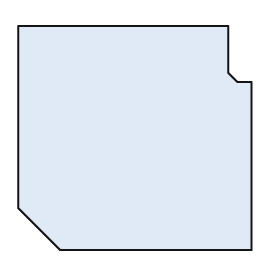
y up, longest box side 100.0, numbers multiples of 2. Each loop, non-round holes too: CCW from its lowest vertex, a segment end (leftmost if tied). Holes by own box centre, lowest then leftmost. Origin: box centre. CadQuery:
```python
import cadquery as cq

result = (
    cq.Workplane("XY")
    .moveTo(-32.0, -48.0)
    .lineTo(50.0, -48.0)
    .lineTo(50.0, 24.0)
    .lineTo(44.0, 24.0)
    .lineTo(40.0, 28.0)
    .lineTo(40.0, 48.0)
    .lineTo(-50.0, 48.0)
    .lineTo(-50.0, -30.0)
    .close()
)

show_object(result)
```